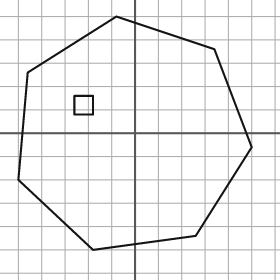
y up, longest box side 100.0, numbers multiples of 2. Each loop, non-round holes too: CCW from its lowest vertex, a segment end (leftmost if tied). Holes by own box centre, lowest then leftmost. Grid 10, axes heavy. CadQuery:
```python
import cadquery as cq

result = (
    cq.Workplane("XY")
    .moveTo(-18.0, -50.0)
    .lineTo(26.0, -44.0)
    .lineTo(50.0, -6.0)
    .lineTo(34.0, 36.0)
    .lineTo(-8.0, 50.0)
    .lineTo(-46.0, 26.0)
    .lineTo(-50.0, -20.0)
    .close()
    .moveTo(-26.0, 8.0)
    .lineTo(-18.0, 8.0)
    .lineTo(-18.0, 16.0)
    .lineTo(-26.0, 16.0)
    .close()
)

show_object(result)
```